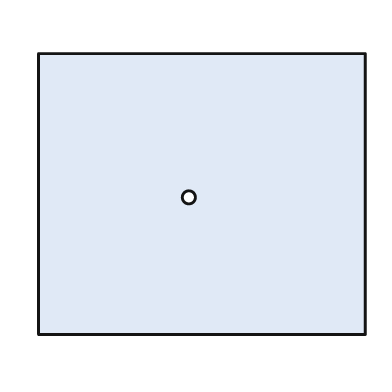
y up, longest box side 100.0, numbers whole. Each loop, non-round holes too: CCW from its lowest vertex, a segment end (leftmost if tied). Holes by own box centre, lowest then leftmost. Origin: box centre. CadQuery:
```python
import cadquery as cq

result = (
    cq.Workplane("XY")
    .moveTo(-50.0, -43.0)
    .lineTo(50.0, -43.0)
    .lineTo(50.0, 43.0)
    .lineTo(-50.0, 43.0)
    .close()
    .moveTo(-4.0, -1.0)
    .circle(2.0)
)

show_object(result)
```